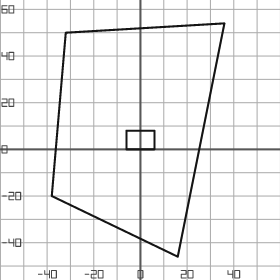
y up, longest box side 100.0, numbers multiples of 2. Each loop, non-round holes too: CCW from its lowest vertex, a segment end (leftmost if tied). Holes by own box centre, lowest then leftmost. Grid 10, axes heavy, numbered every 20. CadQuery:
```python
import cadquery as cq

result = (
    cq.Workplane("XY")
    .moveTo(16.0, -46.0)
    .lineTo(36.0, 54.0)
    .lineTo(-32.0, 50.0)
    .lineTo(-38.0, -20.0)
    .close()
    .moveTo(-6.0, 0.0)
    .lineTo(6.0, 0.0)
    .lineTo(6.0, 8.0)
    .lineTo(-6.0, 8.0)
    .close()
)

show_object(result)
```